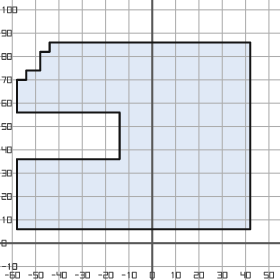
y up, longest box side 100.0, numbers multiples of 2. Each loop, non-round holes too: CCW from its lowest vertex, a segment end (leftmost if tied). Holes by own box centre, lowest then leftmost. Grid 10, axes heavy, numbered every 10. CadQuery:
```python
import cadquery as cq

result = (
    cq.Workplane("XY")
    .moveTo(-58.0, 6.0)
    .lineTo(42.0, 6.0)
    .lineTo(42.0, 86.0)
    .lineTo(-44.0, 86.0)
    .lineTo(-44.0, 82.0)
    .lineTo(-48.0, 82.0)
    .lineTo(-48.0, 74.0)
    .lineTo(-54.0, 74.0)
    .lineTo(-54.0, 70.0)
    .lineTo(-58.0, 70.0)
    .lineTo(-58.0, 56.0)
    .lineTo(-14.0, 56.0)
    .lineTo(-14.0, 36.0)
    .lineTo(-58.0, 36.0)
    .close()
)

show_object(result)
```